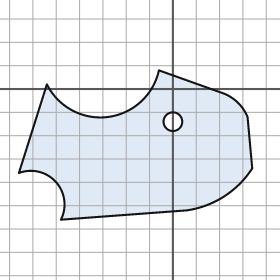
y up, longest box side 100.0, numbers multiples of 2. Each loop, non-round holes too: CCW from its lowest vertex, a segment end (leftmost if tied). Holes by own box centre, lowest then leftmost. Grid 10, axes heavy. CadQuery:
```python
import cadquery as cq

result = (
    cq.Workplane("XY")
    .moveTo(-48.0, -56.0)
    .lineTo(6.0, -52.0)
    .threePointArc((22.0, -46.0), (34.0, -34.0))
    .lineTo(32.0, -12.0)
    .threePointArc((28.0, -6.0), (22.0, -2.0))
    .lineTo(-6.0, 8.0)
    .threePointArc((-28.0, -12.0), (-54.0, 2.0))
    .lineTo(-66.0, -36.0)
    .threePointArc((-50.0, -40.0), (-48.0, -56.0))
    .close()
    .moveTo(0.0, -14.0)
    .circle(4.0)
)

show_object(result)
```